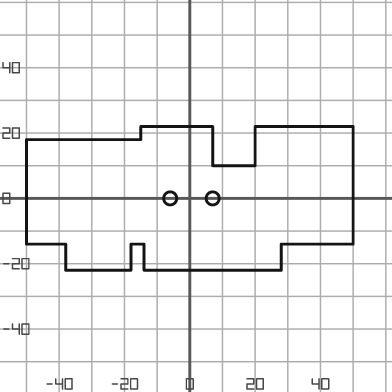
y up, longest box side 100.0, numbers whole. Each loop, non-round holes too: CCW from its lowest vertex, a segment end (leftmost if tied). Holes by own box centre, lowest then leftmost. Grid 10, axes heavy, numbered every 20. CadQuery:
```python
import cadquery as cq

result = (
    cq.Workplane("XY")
    .moveTo(-38.0, -22.0)
    .lineTo(-18.0, -22.0)
    .lineTo(-18.0, -14.0)
    .lineTo(-14.0, -14.0)
    .lineTo(-14.0, -22.0)
    .lineTo(28.0, -22.0)
    .lineTo(28.0, -14.0)
    .lineTo(50.0, -14.0)
    .lineTo(50.0, 22.0)
    .lineTo(20.0, 22.0)
    .lineTo(20.0, 10.0)
    .lineTo(7.0, 10.0)
    .lineTo(7.0, 22.0)
    .lineTo(-15.0, 22.0)
    .lineTo(-15.0, 18.0)
    .lineTo(-50.0, 18.0)
    .lineTo(-50.0, -14.0)
    .lineTo(-38.0, -14.0)
    .close()
    .moveTo(-6.0, 0.0)
    .circle(2.0)
    .moveTo(7.0, 0.0)
    .circle(2.0)
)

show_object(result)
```